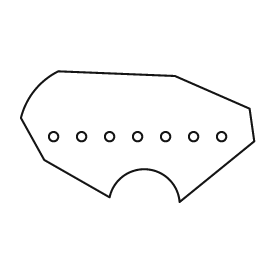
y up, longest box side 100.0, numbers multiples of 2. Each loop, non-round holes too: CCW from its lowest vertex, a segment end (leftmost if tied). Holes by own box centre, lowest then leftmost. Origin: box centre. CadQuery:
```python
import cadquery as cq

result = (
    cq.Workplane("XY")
    .moveTo(18.0, -28.0)
    .lineTo(50.0, -2.0)
    .lineTo(48.0, 12.0)
    .lineTo(16.0, 26.0)
    .lineTo(-34.0, 28.0)
    .threePointArc((-44.0, 20.0), (-50.0, 8.0))
    .lineTo(-40.0, -10.0)
    .lineTo(-12.0, -26.0)
    .threePointArc((4.0, -14.0), (18.0, -28.0))
    .close()
    .moveTo(-36.0, 0.0)
    .circle(2.0)
    .moveTo(-24.0, 0.0)
    .circle(2.0)
    .moveTo(-12.0, 0.0)
    .circle(2.0)
    .moveTo(0.0, 0.0)
    .circle(2.0)
    .moveTo(12.0, 0.0)
    .circle(2.0)
    .moveTo(24.0, 0.0)
    .circle(2.0)
    .moveTo(36.0, 0.0)
    .circle(2.0)
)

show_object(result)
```